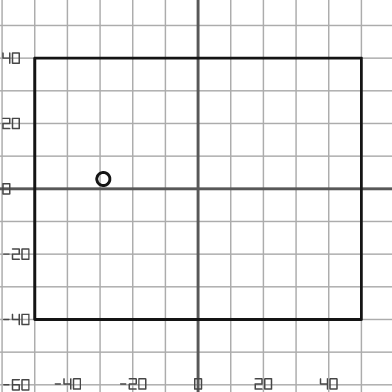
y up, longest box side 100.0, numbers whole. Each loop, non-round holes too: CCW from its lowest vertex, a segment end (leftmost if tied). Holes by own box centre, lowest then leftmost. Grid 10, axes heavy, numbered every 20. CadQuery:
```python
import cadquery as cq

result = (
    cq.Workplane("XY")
    .moveTo(-50.0, -40.0)
    .lineTo(50.0, -40.0)
    .lineTo(50.0, 40.0)
    .lineTo(-50.0, 40.0)
    .close()
    .moveTo(-29.0, 3.0)
    .circle(2.0)
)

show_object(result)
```